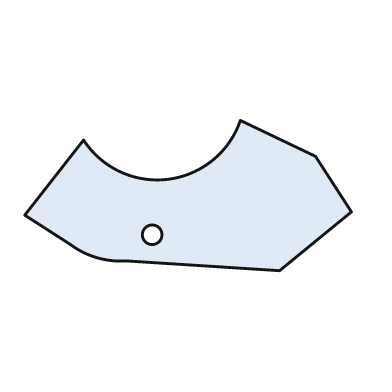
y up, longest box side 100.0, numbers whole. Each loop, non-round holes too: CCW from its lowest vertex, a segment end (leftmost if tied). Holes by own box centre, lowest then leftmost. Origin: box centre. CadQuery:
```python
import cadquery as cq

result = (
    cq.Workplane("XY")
    .moveTo(28.0, -23.0)
    .lineTo(50.0, -5.0)
    .lineTo(39.0, 12.0)
    .lineTo(16.0, 23.0)
    .threePointArc((-6.0, 5.0), (-32.0, 17.0))
    .lineTo(-50.0, -6.0)
    .lineTo(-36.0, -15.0)
    .threePointArc((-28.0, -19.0), (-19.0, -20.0))
    .close()
    .moveTo(-11.0, -12.0)
    .circle(3.0)
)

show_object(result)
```